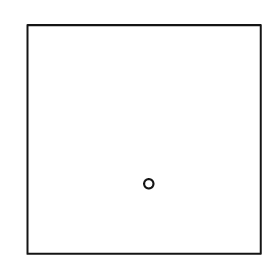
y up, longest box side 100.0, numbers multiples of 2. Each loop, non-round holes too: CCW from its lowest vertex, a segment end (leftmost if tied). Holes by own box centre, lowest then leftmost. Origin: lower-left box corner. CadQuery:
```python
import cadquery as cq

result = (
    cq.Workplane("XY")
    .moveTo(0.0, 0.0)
    .lineTo(100.0, 0.0)
    .lineTo(100.0, 98.0)
    .lineTo(0.0, 98.0)
    .close()
    .moveTo(52.0, 30.0)
    .circle(2.0)
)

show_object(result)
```